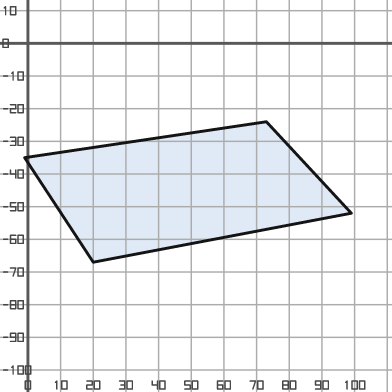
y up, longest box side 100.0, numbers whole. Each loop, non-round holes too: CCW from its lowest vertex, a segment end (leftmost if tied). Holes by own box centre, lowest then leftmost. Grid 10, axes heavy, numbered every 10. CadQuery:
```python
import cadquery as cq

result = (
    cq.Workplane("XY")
    .moveTo(20.0, -67.0)
    .lineTo(99.0, -52.0)
    .lineTo(73.0, -24.0)
    .lineTo(-1.0, -35.0)
    .close()
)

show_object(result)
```